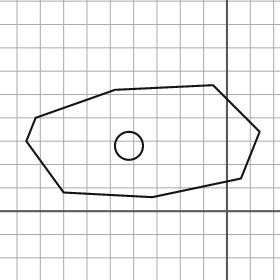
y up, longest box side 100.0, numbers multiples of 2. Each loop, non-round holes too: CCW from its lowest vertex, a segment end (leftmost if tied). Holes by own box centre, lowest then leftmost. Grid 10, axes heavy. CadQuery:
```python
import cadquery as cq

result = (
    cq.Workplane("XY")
    .moveTo(-32.0, 6.0)
    .lineTo(6.0, 14.0)
    .lineTo(14.0, 34.0)
    .lineTo(-6.0, 54.0)
    .lineTo(-48.0, 52.0)
    .lineTo(-82.0, 40.0)
    .lineTo(-86.0, 30.0)
    .lineTo(-70.0, 8.0)
    .close()
    .moveTo(-42.0, 28.0)
    .circle(6.0)
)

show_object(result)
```